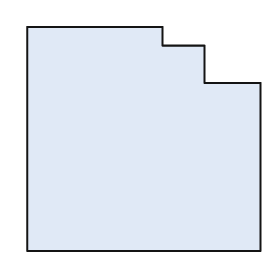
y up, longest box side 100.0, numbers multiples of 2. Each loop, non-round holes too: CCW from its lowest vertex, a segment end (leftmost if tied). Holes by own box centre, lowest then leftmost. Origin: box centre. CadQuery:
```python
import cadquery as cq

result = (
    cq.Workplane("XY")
    .moveTo(-50.0, -48.0)
    .lineTo(50.0, -48.0)
    .lineTo(50.0, 24.0)
    .lineTo(26.0, 24.0)
    .lineTo(26.0, 40.0)
    .lineTo(8.0, 40.0)
    .lineTo(8.0, 48.0)
    .lineTo(-50.0, 48.0)
    .close()
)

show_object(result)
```